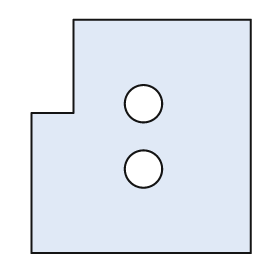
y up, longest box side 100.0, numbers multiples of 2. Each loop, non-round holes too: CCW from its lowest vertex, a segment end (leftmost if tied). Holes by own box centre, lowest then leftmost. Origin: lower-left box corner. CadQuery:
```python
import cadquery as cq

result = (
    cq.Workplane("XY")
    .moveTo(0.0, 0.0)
    .lineTo(94.0, 0.0)
    .lineTo(94.0, 100.0)
    .lineTo(18.0, 100.0)
    .lineTo(18.0, 60.0)
    .lineTo(0.0, 60.0)
    .close()
    .moveTo(48.0, 36.0)
    .circle(8.0)
    .moveTo(48.0, 64.0)
    .circle(8.0)
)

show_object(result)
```